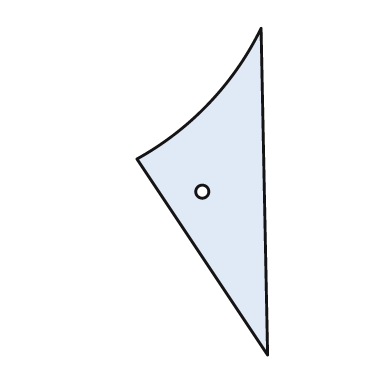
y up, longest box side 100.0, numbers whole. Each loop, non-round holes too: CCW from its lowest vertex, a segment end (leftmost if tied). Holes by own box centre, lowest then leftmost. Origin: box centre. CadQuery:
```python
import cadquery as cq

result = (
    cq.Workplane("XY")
    .moveTo(20.0, -50.0)
    .lineTo(18.0, 50.0)
    .threePointArc((2.0, 27.0), (-20.0, 10.0))
    .close()
    .moveTo(0.0, 0.0)
    .circle(2.0)
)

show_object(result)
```